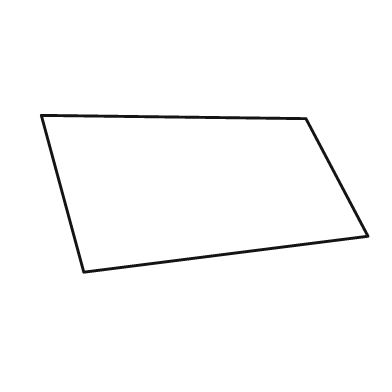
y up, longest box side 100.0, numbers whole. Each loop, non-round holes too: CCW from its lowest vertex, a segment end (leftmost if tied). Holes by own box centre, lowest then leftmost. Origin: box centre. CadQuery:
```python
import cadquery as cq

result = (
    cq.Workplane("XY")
    .moveTo(-37.0, -24.0)
    .lineTo(50.0, -13.0)
    .lineTo(31.0, 23.0)
    .lineTo(-50.0, 24.0)
    .close()
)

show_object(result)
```